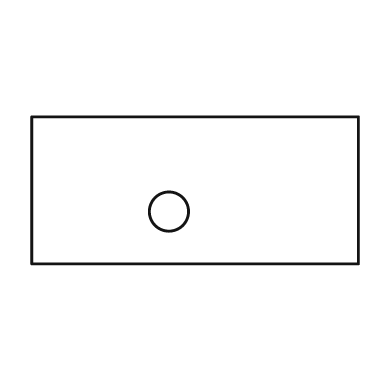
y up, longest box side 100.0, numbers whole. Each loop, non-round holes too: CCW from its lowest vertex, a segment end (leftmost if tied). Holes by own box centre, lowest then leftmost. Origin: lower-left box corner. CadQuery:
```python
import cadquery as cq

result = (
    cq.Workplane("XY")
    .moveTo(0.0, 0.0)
    .lineTo(100.0, 0.0)
    .lineTo(100.0, 45.0)
    .lineTo(0.0, 45.0)
    .close()
    .moveTo(42.0, 16.0)
    .circle(6.0)
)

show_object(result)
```